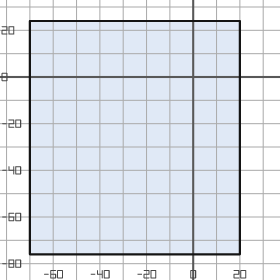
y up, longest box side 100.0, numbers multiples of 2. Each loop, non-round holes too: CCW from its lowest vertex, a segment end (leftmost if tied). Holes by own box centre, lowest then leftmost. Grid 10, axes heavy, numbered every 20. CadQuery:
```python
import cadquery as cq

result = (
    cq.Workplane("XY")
    .moveTo(-70.0, -76.0)
    .lineTo(20.0, -76.0)
    .lineTo(20.0, 24.0)
    .lineTo(-70.0, 24.0)
    .close()
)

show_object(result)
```